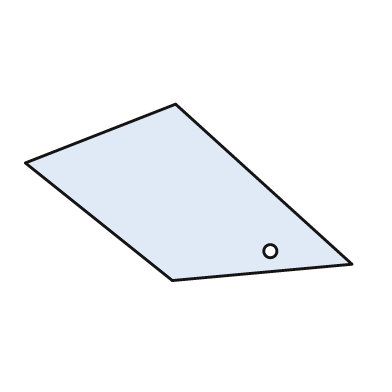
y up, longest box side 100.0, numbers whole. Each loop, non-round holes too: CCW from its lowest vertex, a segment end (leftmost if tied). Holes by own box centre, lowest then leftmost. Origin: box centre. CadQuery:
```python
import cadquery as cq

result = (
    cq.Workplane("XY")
    .moveTo(-5.0, -27.0)
    .lineTo(50.0, -22.0)
    .lineTo(-4.0, 27.0)
    .lineTo(-50.0, 9.0)
    .close()
    .moveTo(25.0, -18.0)
    .circle(2.0)
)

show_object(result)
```